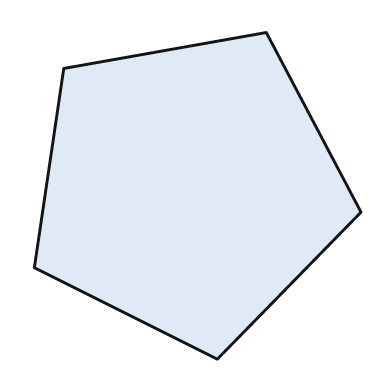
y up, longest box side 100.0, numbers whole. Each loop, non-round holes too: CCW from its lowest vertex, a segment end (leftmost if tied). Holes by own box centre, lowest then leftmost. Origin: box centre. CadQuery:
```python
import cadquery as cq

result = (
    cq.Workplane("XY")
    .moveTo(6.0, -50.0)
    .lineTo(50.0, -5.0)
    .lineTo(21.0, 50.0)
    .lineTo(-41.0, 39.0)
    .lineTo(-50.0, -22.0)
    .close()
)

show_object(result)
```